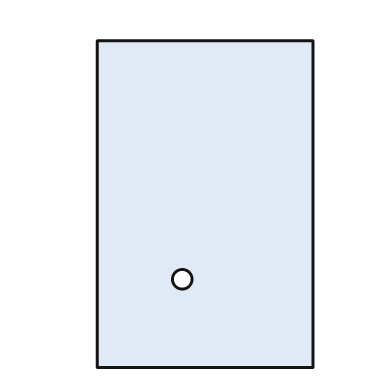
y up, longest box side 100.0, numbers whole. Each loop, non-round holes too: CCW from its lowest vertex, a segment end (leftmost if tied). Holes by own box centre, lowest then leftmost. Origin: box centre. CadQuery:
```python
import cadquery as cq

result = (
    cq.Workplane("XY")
    .moveTo(-33.0, -50.0)
    .lineTo(33.0, -50.0)
    .lineTo(33.0, 50.0)
    .lineTo(-33.0, 50.0)
    .close()
    .moveTo(-7.0, -23.0)
    .circle(3.0)
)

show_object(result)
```